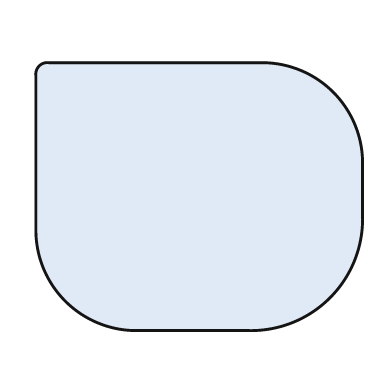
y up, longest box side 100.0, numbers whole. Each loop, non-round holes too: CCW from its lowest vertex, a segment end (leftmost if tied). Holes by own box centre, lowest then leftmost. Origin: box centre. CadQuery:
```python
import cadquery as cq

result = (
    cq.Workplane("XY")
    .moveTo(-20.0, -41.0)
    .lineTo(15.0, -41.0)
    .threePointArc((40.0, -31.0), (50.0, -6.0))
    .lineTo(50.0, 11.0)
    .threePointArc((41.0, 32.0), (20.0, 41.0))
    .lineTo(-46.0, 41.0)
    .threePointArc((-49.0, 40.0), (-50.0, 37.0))
    .lineTo(-50.0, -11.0)
    .threePointArc((-41.0, -32.0), (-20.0, -41.0))
    .close()
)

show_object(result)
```